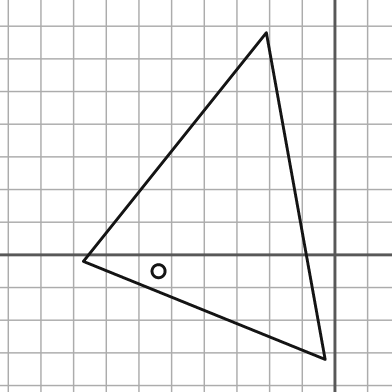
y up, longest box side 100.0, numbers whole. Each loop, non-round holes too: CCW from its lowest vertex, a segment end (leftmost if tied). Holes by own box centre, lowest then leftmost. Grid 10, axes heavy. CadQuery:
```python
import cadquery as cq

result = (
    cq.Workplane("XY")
    .moveTo(-3.0, -32.0)
    .lineTo(-21.0, 68.0)
    .lineTo(-77.0, -2.0)
    .close()
    .moveTo(-54.0, -5.0)
    .circle(2.0)
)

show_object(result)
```